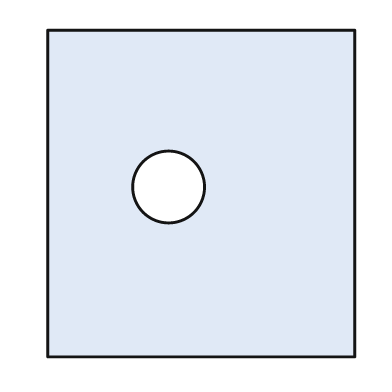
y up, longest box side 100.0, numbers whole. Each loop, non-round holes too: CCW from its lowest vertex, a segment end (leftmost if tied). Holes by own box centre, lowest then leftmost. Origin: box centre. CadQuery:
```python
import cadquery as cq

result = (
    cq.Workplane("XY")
    .moveTo(-47.0, -50.0)
    .lineTo(47.0, -50.0)
    .lineTo(47.0, 50.0)
    .lineTo(-47.0, 50.0)
    .close()
    .moveTo(-10.0, 2.0)
    .circle(11.0)
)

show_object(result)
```